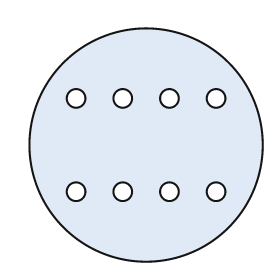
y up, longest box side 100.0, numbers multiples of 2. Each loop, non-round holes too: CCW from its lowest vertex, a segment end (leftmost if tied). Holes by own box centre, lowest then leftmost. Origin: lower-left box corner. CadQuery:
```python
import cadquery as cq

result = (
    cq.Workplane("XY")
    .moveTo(50.0, 50.0)
    .circle(50.0)
    .moveTo(20.0, 30.0)
    .circle(4.0)
    .moveTo(40.0, 30.0)
    .circle(4.0)
    .moveTo(60.0, 30.0)
    .circle(4.0)
    .moveTo(80.0, 30.0)
    .circle(4.0)
    .moveTo(20.0, 70.0)
    .circle(4.0)
    .moveTo(40.0, 70.0)
    .circle(4.0)
    .moveTo(60.0, 70.0)
    .circle(4.0)
    .moveTo(80.0, 70.0)
    .circle(4.0)
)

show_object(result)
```